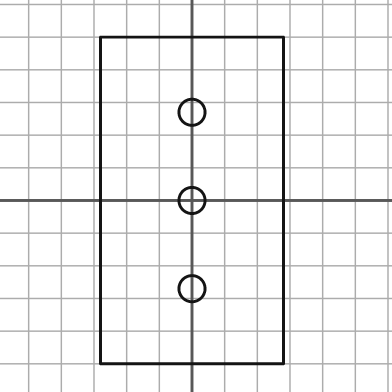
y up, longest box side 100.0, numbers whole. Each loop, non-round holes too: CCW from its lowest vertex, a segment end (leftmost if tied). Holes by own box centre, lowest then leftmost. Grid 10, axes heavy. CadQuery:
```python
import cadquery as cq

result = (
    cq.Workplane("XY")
    .moveTo(-28.0, -50.0)
    .lineTo(28.0, -50.0)
    .lineTo(28.0, 50.0)
    .lineTo(-28.0, 50.0)
    .close()
    .moveTo(0.0, -27.0)
    .circle(4.0)
    .moveTo(0.0, 0.0)
    .circle(4.0)
    .moveTo(0.0, 27.0)
    .circle(4.0)
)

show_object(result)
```